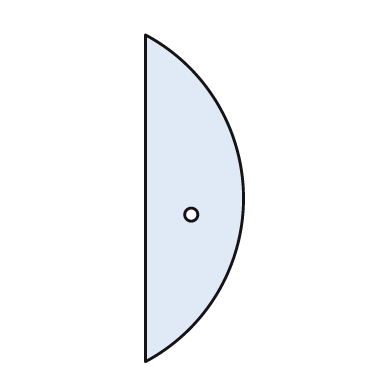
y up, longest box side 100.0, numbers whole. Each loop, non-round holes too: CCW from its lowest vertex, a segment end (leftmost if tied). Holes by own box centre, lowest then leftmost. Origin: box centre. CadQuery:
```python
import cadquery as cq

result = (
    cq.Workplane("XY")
    .moveTo(-15.0, -50.0)
    .threePointArc((15.0, 0.0), (-15.0, 50.0))
    .close()
    .moveTo(-1.0, -5.0)
    .circle(2.0)
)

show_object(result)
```